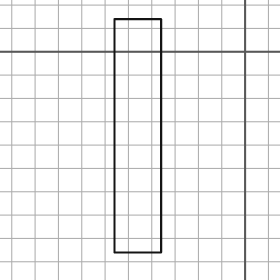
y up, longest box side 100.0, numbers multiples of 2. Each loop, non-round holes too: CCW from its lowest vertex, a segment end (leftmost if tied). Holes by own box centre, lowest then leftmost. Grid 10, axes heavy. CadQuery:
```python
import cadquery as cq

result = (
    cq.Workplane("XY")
    .moveTo(-56.0, -86.0)
    .lineTo(-36.0, -86.0)
    .lineTo(-36.0, 14.0)
    .lineTo(-56.0, 14.0)
    .close()
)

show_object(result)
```